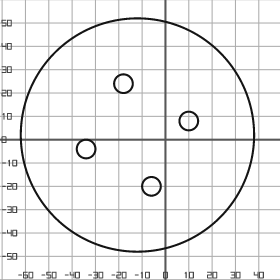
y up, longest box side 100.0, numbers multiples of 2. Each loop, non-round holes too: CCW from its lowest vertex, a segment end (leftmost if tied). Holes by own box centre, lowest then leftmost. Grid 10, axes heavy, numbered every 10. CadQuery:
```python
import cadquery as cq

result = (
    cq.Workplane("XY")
    .moveTo(-12.0, 2.0)
    .circle(50.0)
    .moveTo(-6.0, -20.0)
    .circle(4.0)
    .moveTo(-34.0, -4.0)
    .circle(4.0)
    .moveTo(10.0, 8.0)
    .circle(4.0)
    .moveTo(-18.0, 24.0)
    .circle(4.0)
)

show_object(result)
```